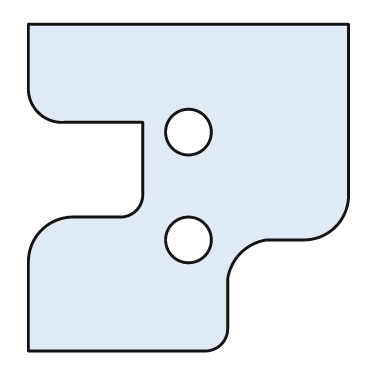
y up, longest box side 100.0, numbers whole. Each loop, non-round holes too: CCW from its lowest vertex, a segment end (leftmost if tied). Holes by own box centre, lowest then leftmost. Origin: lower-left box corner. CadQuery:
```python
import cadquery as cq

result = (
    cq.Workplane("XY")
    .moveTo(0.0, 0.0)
    .lineTo(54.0, 0.0)
    .threePointArc((59.0, 2.0), (61.0, 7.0))
    .lineTo(61.0, 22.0)
    .threePointArc((65.0, 30.0), (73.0, 34.0))
    .lineTo(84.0, 34.0)
    .threePointArc((94.0, 38.0), (98.0, 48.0))
    .lineTo(98.0, 100.0)
    .lineTo(0.0, 100.0)
    .lineTo(0.0, 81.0)
    .threePointArc((3.0, 73.0), (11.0, 70.0))
    .lineTo(35.0, 70.0)
    .lineTo(35.0, 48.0)
    .threePointArc((33.0, 43.0), (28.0, 41.0))
    .lineTo(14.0, 41.0)
    .threePointArc((4.0, 37.0), (0.0, 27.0))
    .close()
    .moveTo(49.0, 34.0)
    .circle(7.0)
    .moveTo(49.0, 67.0)
    .circle(7.0)
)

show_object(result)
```